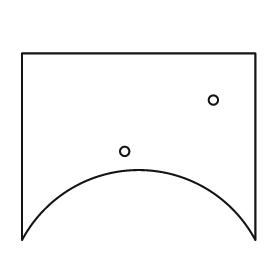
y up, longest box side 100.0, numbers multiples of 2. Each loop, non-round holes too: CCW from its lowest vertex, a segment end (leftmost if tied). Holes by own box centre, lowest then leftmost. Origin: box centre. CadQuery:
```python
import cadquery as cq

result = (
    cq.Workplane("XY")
    .moveTo(-50.0, -40.0)
    .threePointArc((0.0, -10.0), (50.0, -40.0))
    .lineTo(50.0, 40.0)
    .lineTo(-50.0, 40.0)
    .close()
    .moveTo(-6.0, -2.0)
    .circle(2.0)
    .moveTo(32.0, 20.0)
    .circle(2.0)
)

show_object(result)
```